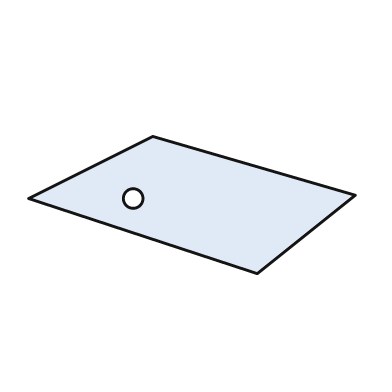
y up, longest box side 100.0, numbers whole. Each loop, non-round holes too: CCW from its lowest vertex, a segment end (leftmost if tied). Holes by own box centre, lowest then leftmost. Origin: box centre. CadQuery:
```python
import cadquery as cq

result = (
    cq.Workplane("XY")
    .moveTo(20.0, -21.0)
    .lineTo(50.0, 3.0)
    .lineTo(-12.0, 21.0)
    .lineTo(-50.0, 2.0)
    .close()
    .moveTo(-18.0, 2.0)
    .circle(3.0)
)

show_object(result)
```